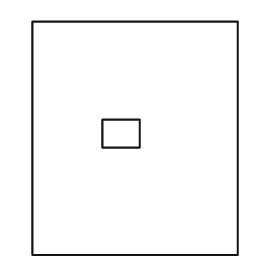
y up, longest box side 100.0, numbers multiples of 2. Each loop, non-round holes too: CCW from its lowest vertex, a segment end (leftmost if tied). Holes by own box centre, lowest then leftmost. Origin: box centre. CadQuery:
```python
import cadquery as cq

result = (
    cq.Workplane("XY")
    .moveTo(-44.0, -50.0)
    .lineTo(44.0, -50.0)
    .lineTo(44.0, 50.0)
    .lineTo(-44.0, 50.0)
    .close()
    .moveTo(-14.0, -4.0)
    .lineTo(2.0, -4.0)
    .lineTo(2.0, 8.0)
    .lineTo(-14.0, 8.0)
    .close()
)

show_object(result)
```